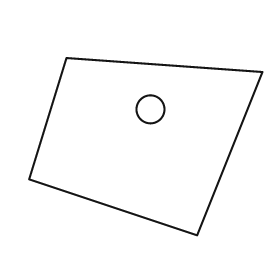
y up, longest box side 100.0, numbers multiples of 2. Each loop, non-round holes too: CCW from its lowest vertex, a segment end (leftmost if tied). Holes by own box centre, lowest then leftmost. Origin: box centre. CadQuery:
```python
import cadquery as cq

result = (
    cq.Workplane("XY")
    .moveTo(22.0, -38.0)
    .lineTo(50.0, 32.0)
    .lineTo(-34.0, 38.0)
    .lineTo(-50.0, -14.0)
    .close()
    .moveTo(2.0, 16.0)
    .circle(6.0)
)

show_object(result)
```